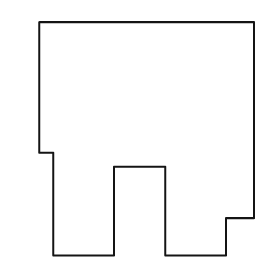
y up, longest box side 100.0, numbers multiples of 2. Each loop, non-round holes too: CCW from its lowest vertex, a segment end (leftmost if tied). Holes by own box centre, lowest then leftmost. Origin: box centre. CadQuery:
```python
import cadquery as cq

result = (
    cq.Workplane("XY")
    .moveTo(-40.0, -50.0)
    .lineTo(-14.0, -50.0)
    .lineTo(-14.0, -12.0)
    .lineTo(8.0, -12.0)
    .lineTo(8.0, -50.0)
    .lineTo(34.0, -50.0)
    .lineTo(34.0, -34.0)
    .lineTo(46.0, -34.0)
    .lineTo(46.0, 50.0)
    .lineTo(-46.0, 50.0)
    .lineTo(-46.0, -6.0)
    .lineTo(-40.0, -6.0)
    .close()
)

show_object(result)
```